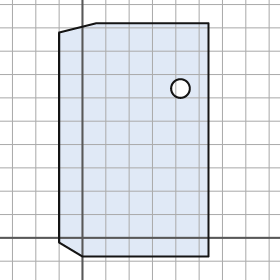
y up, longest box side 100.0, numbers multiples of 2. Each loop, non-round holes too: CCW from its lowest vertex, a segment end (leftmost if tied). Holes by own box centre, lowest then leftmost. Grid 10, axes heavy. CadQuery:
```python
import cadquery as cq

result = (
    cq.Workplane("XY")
    .moveTo(0.0, -8.0)
    .lineTo(54.0, -8.0)
    .lineTo(54.0, 92.0)
    .lineTo(6.0, 92.0)
    .lineTo(-10.0, 88.0)
    .lineTo(-10.0, -2.0)
    .close()
    .moveTo(42.0, 64.0)
    .circle(4.0)
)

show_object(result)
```